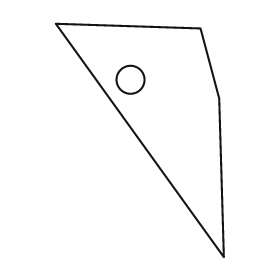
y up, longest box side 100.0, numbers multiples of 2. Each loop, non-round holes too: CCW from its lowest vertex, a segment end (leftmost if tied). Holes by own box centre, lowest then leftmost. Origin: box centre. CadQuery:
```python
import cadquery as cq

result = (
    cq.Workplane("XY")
    .moveTo(36.0, -50.0)
    .lineTo(34.0, 18.0)
    .lineTo(26.0, 48.0)
    .lineTo(-36.0, 50.0)
    .close()
    .moveTo(-4.0, 26.0)
    .circle(6.0)
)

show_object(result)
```